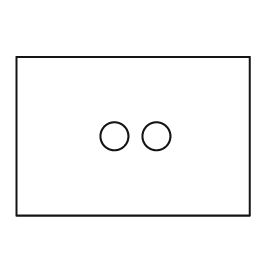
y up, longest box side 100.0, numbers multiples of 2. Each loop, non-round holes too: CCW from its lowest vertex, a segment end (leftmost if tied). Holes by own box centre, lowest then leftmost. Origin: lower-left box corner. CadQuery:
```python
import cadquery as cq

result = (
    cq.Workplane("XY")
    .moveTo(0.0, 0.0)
    .lineTo(100.0, 0.0)
    .lineTo(100.0, 68.0)
    .lineTo(0.0, 68.0)
    .close()
    .moveTo(42.0, 34.0)
    .circle(6.0)
    .moveTo(60.0, 34.0)
    .circle(6.0)
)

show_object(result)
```